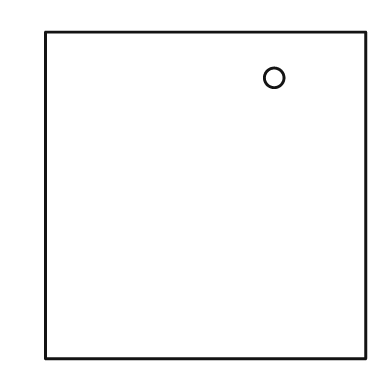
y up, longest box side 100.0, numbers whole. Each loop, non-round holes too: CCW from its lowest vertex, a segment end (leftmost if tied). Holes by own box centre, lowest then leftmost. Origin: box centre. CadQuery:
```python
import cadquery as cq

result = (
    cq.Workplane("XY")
    .moveTo(-49.0, -50.0)
    .lineTo(49.0, -50.0)
    .lineTo(49.0, 50.0)
    .lineTo(-49.0, 50.0)
    .close()
    .moveTo(21.0, 36.0)
    .circle(3.0)
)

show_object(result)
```